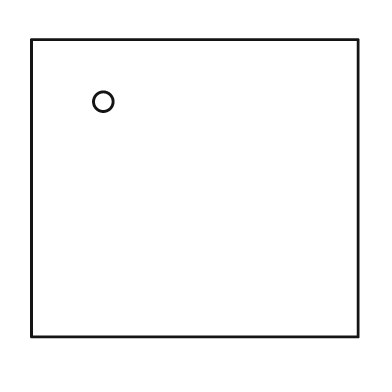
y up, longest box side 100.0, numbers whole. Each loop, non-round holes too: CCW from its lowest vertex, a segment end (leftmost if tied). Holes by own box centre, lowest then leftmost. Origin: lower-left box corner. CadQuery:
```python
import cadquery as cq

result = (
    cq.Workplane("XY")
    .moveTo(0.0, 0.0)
    .lineTo(100.0, 0.0)
    .lineTo(100.0, 91.0)
    .lineTo(0.0, 91.0)
    .close()
    .moveTo(22.0, 72.0)
    .circle(3.0)
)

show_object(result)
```